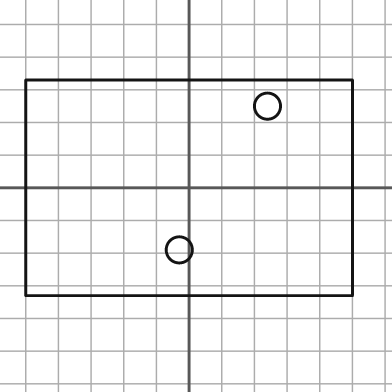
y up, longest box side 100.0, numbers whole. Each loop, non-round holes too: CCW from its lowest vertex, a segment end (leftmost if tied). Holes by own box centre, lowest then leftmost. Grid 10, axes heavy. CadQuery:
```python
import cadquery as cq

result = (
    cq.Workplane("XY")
    .moveTo(-50.0, -33.0)
    .lineTo(50.0, -33.0)
    .lineTo(50.0, 33.0)
    .lineTo(-50.0, 33.0)
    .close()
    .moveTo(-3.0, -19.0)
    .circle(4.0)
    .moveTo(24.0, 25.0)
    .circle(4.0)
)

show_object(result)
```